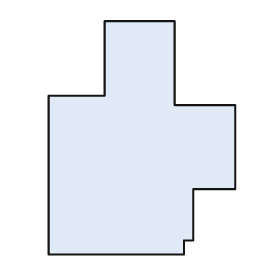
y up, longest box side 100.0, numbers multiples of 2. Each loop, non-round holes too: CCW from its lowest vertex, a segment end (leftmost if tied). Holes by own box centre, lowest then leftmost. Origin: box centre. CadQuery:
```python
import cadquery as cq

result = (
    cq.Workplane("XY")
    .moveTo(-40.0, -50.0)
    .lineTo(18.0, -50.0)
    .lineTo(18.0, -44.0)
    .lineTo(22.0, -44.0)
    .lineTo(22.0, -22.0)
    .lineTo(40.0, -22.0)
    .lineTo(40.0, 14.0)
    .lineTo(14.0, 14.0)
    .lineTo(14.0, 50.0)
    .lineTo(-16.0, 50.0)
    .lineTo(-16.0, 18.0)
    .lineTo(-40.0, 18.0)
    .close()
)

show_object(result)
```